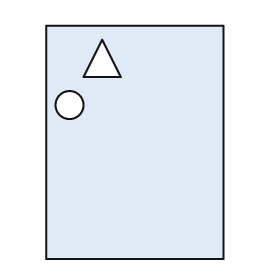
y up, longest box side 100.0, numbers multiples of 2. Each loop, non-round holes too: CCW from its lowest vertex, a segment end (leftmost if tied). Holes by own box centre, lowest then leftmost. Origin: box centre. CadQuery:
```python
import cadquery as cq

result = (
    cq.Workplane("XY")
    .moveTo(-38.0, -50.0)
    .lineTo(38.0, -50.0)
    .lineTo(38.0, 50.0)
    .lineTo(-38.0, 50.0)
    .close()
    .moveTo(-28.0, 16.0)
    .circle(6.0)
    .moveTo(-22.0, 28.0)
    .lineTo(-6.0, 28.0)
    .lineTo(-14.0, 44.0)
    .close()
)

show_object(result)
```